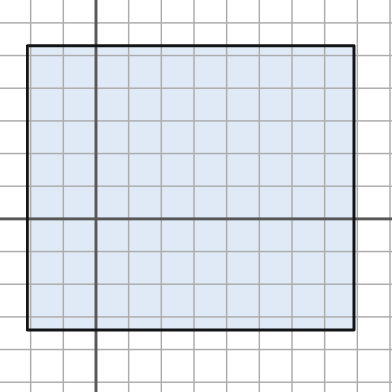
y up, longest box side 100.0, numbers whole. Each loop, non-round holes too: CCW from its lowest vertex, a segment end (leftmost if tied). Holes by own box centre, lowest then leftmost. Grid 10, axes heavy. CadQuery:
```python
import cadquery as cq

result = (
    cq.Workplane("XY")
    .moveTo(-21.0, -34.0)
    .lineTo(79.0, -34.0)
    .lineTo(79.0, 53.0)
    .lineTo(-21.0, 53.0)
    .close()
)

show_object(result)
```